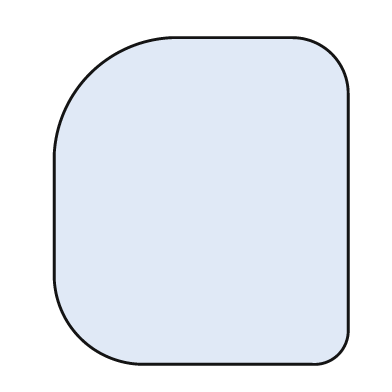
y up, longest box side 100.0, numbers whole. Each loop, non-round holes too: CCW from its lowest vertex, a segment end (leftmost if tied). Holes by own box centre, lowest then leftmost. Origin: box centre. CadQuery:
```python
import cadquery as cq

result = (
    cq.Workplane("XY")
    .moveTo(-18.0, -50.0)
    .lineTo(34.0, -50.0)
    .threePointArc((42.0, -47.0), (45.0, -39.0))
    .lineTo(45.0, 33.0)
    .threePointArc((40.0, 45.0), (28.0, 50.0))
    .lineTo(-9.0, 50.0)
    .threePointArc((-34.0, 39.0), (-45.0, 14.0))
    .lineTo(-45.0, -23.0)
    .threePointArc((-37.0, -42.0), (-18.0, -50.0))
    .close()
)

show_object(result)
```